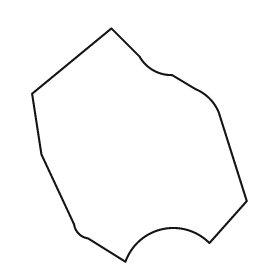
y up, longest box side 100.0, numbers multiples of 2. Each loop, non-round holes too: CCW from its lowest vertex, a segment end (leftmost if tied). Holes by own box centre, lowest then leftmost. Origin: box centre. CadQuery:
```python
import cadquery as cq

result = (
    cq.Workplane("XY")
    .moveTo(-6.0, -50.0)
    .threePointArc((10.0, -36.0), (30.0, -42.0))
    .lineTo(46.0, -24.0)
    .lineTo(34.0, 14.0)
    .threePointArc((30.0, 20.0), (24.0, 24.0))
    .lineTo(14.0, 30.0)
    .threePointArc((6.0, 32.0), (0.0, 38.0))
    .lineTo(-12.0, 50.0)
    .lineTo(-46.0, 22.0)
    .lineTo(-42.0, -4.0)
    .lineTo(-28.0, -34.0)
    .threePointArc((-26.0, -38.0), (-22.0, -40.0))
    .close()
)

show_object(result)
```